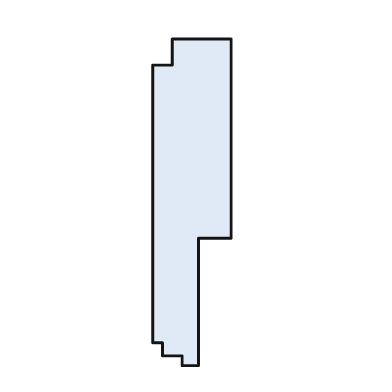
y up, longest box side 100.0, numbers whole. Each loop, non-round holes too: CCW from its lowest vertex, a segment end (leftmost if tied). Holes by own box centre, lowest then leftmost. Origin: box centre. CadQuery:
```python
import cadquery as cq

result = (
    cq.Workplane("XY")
    .moveTo(-3.0, -50.0)
    .lineTo(2.0, -50.0)
    .lineTo(2.0, -11.0)
    .lineTo(12.0, -11.0)
    .lineTo(12.0, 50.0)
    .lineTo(-6.0, 50.0)
    .lineTo(-6.0, 42.0)
    .lineTo(-12.0, 42.0)
    .lineTo(-12.0, -43.0)
    .lineTo(-9.0, -43.0)
    .lineTo(-9.0, -47.0)
    .lineTo(-3.0, -47.0)
    .close()
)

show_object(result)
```